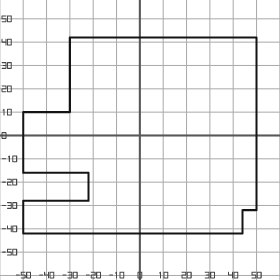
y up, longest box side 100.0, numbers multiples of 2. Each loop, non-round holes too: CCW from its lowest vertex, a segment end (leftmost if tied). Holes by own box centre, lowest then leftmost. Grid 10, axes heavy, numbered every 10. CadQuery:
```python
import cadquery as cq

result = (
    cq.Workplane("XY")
    .moveTo(-50.0, -42.0)
    .lineTo(44.0, -42.0)
    .lineTo(44.0, -32.0)
    .lineTo(50.0, -32.0)
    .lineTo(50.0, 42.0)
    .lineTo(-30.0, 42.0)
    .lineTo(-30.0, 10.0)
    .lineTo(-50.0, 10.0)
    .lineTo(-50.0, -16.0)
    .lineTo(-22.0, -16.0)
    .lineTo(-22.0, -28.0)
    .lineTo(-50.0, -28.0)
    .close()
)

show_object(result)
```